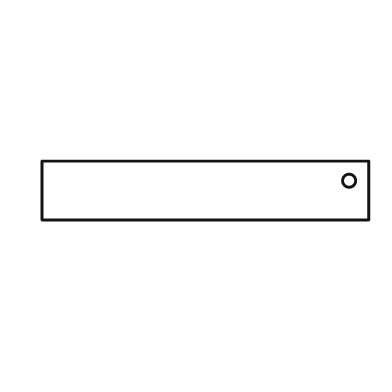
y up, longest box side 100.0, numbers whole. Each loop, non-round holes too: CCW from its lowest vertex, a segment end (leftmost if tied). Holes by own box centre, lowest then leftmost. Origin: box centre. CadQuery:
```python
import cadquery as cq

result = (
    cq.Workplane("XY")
    .moveTo(-50.0, -9.0)
    .lineTo(50.0, -9.0)
    .lineTo(50.0, 9.0)
    .lineTo(-50.0, 9.0)
    .close()
    .moveTo(44.0, 3.0)
    .circle(2.0)
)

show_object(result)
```